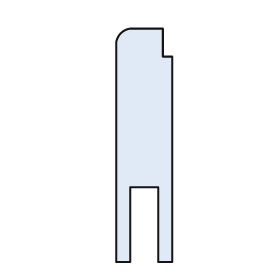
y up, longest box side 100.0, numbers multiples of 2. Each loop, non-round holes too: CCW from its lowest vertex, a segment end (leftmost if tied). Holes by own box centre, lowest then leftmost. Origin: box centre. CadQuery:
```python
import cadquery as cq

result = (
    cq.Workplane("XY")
    .moveTo(-12.0, -50.0)
    .lineTo(-6.0, -50.0)
    .lineTo(-6.0, -18.0)
    .lineTo(6.0, -18.0)
    .lineTo(6.0, -50.0)
    .lineTo(12.0, -50.0)
    .lineTo(12.0, 38.0)
    .lineTo(8.0, 38.0)
    .lineTo(8.0, 50.0)
    .lineTo(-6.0, 50.0)
    .threePointArc((-10.0, 48.0), (-12.0, 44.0))
    .close()
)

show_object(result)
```